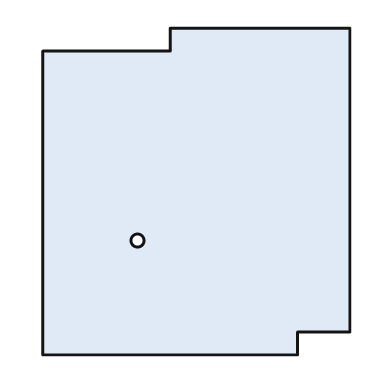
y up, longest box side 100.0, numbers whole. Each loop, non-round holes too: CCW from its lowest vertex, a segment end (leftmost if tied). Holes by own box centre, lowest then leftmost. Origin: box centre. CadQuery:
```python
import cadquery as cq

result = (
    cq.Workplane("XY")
    .moveTo(-47.0, -50.0)
    .lineTo(31.0, -50.0)
    .lineTo(31.0, -43.0)
    .lineTo(47.0, -43.0)
    .lineTo(47.0, 50.0)
    .lineTo(-8.0, 50.0)
    .lineTo(-8.0, 43.0)
    .lineTo(-47.0, 43.0)
    .close()
    .moveTo(-18.0, -15.0)
    .circle(2.0)
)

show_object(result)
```